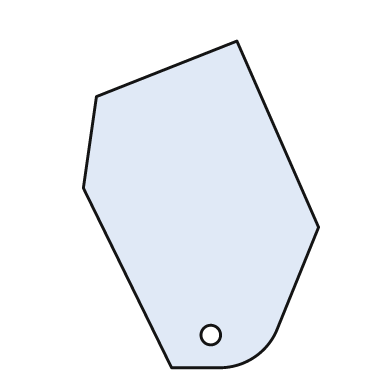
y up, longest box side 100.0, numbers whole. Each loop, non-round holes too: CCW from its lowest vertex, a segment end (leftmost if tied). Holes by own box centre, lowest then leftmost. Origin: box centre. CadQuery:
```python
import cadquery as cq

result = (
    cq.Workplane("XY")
    .moveTo(-9.0, -50.0)
    .lineTo(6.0, -50.0)
    .threePointArc((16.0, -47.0), (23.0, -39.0))
    .lineTo(36.0, -7.0)
    .lineTo(11.0, 50.0)
    .lineTo(-32.0, 33.0)
    .lineTo(-36.0, 5.0)
    .close()
    .moveTo(3.0, -40.0)
    .circle(3.0)
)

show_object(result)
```